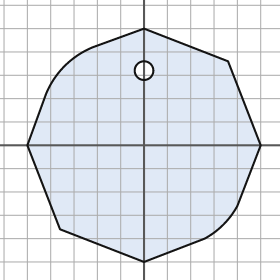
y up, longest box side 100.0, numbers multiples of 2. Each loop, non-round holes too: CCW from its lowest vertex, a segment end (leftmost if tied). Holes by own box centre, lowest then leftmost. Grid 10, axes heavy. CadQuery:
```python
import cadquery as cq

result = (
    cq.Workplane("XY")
    .moveTo(0.0, -50.0)
    .lineTo(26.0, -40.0)
    .threePointArc((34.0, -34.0), (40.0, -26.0))
    .lineTo(50.0, 0.0)
    .lineTo(36.0, 36.0)
    .lineTo(0.0, 50.0)
    .lineTo(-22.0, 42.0)
    .threePointArc((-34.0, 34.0), (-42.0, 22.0))
    .lineTo(-50.0, 0.0)
    .lineTo(-36.0, -36.0)
    .close()
    .moveTo(0.0, 32.0)
    .circle(4.0)
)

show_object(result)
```